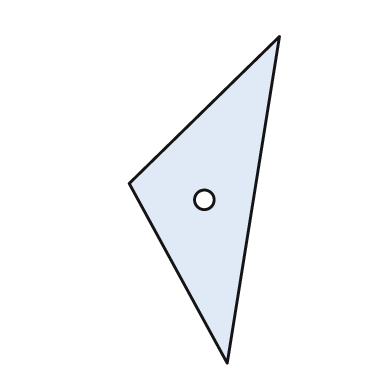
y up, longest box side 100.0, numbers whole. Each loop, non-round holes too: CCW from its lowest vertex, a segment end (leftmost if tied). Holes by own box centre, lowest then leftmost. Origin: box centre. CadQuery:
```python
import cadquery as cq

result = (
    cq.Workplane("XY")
    .moveTo(7.0, -50.0)
    .lineTo(23.0, 50.0)
    .lineTo(-23.0, 5.0)
    .close()
    .moveTo(0.0, 0.0)
    .circle(3.0)
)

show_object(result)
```